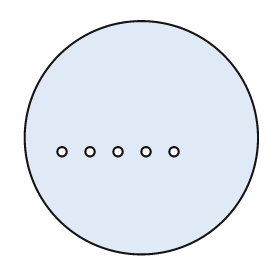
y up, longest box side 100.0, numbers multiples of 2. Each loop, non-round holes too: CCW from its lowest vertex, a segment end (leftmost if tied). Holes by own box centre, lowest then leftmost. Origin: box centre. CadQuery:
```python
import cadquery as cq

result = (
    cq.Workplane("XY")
    .moveTo(0.0, 0.0)
    .circle(50.0)
    .moveTo(-34.0, -6.0)
    .circle(2.0)
    .moveTo(-22.0, -6.0)
    .circle(2.0)
    .moveTo(-10.0, -6.0)
    .circle(2.0)
    .moveTo(2.0, -6.0)
    .circle(2.0)
    .moveTo(14.0, -6.0)
    .circle(2.0)
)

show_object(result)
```